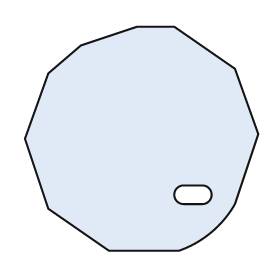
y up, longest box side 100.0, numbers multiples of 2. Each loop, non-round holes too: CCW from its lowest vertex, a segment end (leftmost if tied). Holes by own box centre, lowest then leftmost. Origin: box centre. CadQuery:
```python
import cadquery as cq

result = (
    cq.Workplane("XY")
    .moveTo(-14.0, -48.0)
    .lineTo(16.0, -48.0)
    .threePointArc((30.0, -40.0), (40.0, -28.0))
    .lineTo(50.0, 2.0)
    .lineTo(40.0, 30.0)
    .lineTo(14.0, 48.0)
    .lineTo(-2.0, 48.0)
    .lineTo(-26.0, 40.0)
    .lineTo(-40.0, 28.0)
    .lineTo(-50.0, 0.0)
    .lineTo(-40.0, -30.0)
    .close()
    .moveTo(18.0, -28.0)
    .lineTo(26.0, -28.0)
    .threePointArc((30.0, -24.0), (26.0, -20.0))
    .lineTo(18.0, -20.0)
    .threePointArc((14.0, -24.0), (18.0, -28.0))
    .close()
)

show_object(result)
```